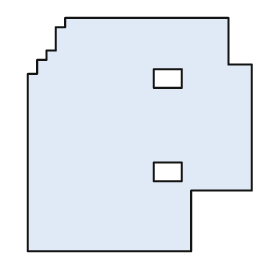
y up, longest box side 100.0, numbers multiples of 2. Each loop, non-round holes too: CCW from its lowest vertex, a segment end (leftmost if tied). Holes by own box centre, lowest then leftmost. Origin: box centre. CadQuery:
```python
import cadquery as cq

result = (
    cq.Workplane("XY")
    .moveTo(-48.0, -50.0)
    .lineTo(22.0, -50.0)
    .lineTo(22.0, -24.0)
    .lineTo(48.0, -24.0)
    .lineTo(48.0, 30.0)
    .lineTo(38.0, 30.0)
    .lineTo(38.0, 50.0)
    .lineTo(-32.0, 50.0)
    .lineTo(-32.0, 46.0)
    .lineTo(-36.0, 46.0)
    .lineTo(-36.0, 36.0)
    .lineTo(-40.0, 36.0)
    .lineTo(-40.0, 32.0)
    .lineTo(-44.0, 32.0)
    .lineTo(-44.0, 26.0)
    .lineTo(-48.0, 26.0)
    .close()
    .moveTo(6.0, -20.0)
    .lineTo(18.0, -20.0)
    .lineTo(18.0, -12.0)
    .lineTo(6.0, -12.0)
    .close()
    .moveTo(6.0, 20.0)
    .lineTo(18.0, 20.0)
    .lineTo(18.0, 28.0)
    .lineTo(6.0, 28.0)
    .close()
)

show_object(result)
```